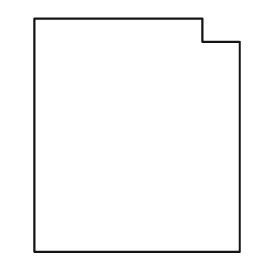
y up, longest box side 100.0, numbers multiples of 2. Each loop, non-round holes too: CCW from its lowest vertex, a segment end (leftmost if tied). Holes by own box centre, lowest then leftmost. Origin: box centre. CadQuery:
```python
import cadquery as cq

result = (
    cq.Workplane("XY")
    .moveTo(-44.0, -50.0)
    .lineTo(44.0, -50.0)
    .lineTo(44.0, 40.0)
    .lineTo(28.0, 40.0)
    .lineTo(28.0, 50.0)
    .lineTo(-44.0, 50.0)
    .close()
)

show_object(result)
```